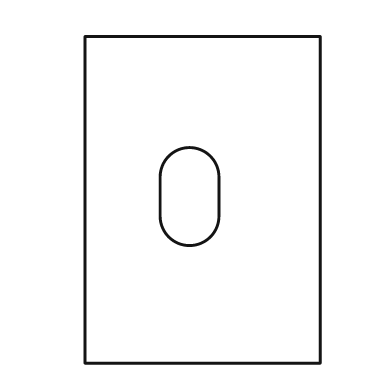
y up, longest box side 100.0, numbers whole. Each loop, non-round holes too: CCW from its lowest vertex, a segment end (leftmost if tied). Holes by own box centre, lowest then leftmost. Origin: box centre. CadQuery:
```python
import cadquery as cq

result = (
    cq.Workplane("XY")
    .moveTo(-36.0, -50.0)
    .lineTo(36.0, -50.0)
    .lineTo(36.0, 50.0)
    .lineTo(-36.0, 50.0)
    .close()
    .moveTo(-13.0, -5.0)
    .threePointArc((-4.0, -14.0), (5.0, -5.0))
    .lineTo(5.0, 7.0)
    .threePointArc((-4.0, 16.0), (-13.0, 7.0))
    .close()
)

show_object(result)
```